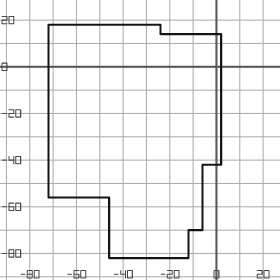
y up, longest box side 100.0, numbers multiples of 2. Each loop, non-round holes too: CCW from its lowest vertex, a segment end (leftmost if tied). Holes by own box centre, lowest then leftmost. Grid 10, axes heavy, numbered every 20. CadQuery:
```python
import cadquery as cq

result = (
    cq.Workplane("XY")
    .moveTo(-46.0, -82.0)
    .lineTo(-12.0, -82.0)
    .lineTo(-12.0, -70.0)
    .lineTo(-6.0, -70.0)
    .lineTo(-6.0, -42.0)
    .lineTo(2.0, -42.0)
    .lineTo(2.0, 14.0)
    .lineTo(-24.0, 14.0)
    .lineTo(-24.0, 18.0)
    .lineTo(-72.0, 18.0)
    .lineTo(-72.0, -56.0)
    .lineTo(-46.0, -56.0)
    .close()
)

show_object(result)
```